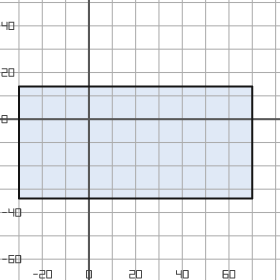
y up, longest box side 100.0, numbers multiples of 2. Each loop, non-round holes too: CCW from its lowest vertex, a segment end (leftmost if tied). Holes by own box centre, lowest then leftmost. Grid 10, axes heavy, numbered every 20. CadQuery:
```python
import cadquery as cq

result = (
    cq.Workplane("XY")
    .moveTo(-30.0, -34.0)
    .lineTo(70.0, -34.0)
    .lineTo(70.0, 14.0)
    .lineTo(-30.0, 14.0)
    .close()
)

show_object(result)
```